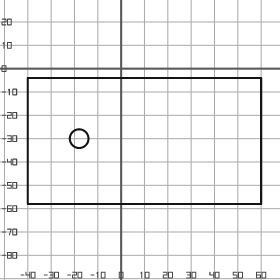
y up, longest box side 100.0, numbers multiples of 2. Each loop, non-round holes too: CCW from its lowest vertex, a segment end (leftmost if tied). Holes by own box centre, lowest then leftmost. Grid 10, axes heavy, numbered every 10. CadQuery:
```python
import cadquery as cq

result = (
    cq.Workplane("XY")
    .moveTo(-40.0, -58.0)
    .lineTo(60.0, -58.0)
    .lineTo(60.0, -4.0)
    .lineTo(-40.0, -4.0)
    .close()
    .moveTo(-18.0, -30.0)
    .circle(4.0)
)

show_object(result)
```